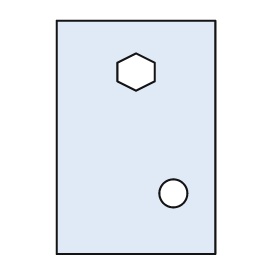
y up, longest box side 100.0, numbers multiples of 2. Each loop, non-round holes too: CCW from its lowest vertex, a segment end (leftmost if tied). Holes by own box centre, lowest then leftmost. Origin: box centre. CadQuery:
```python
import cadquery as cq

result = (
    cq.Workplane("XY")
    .moveTo(-34.0, -50.0)
    .lineTo(34.0, -50.0)
    .lineTo(34.0, 50.0)
    .lineTo(-34.0, 50.0)
    .close()
    .moveTo(16.0, -24.0)
    .circle(6.0)
    .moveTo(0.0, 20.0)
    .lineTo(8.0, 24.0)
    .lineTo(8.0, 32.0)
    .lineTo(0.0, 36.0)
    .lineTo(-8.0, 32.0)
    .lineTo(-8.0, 24.0)
    .close()
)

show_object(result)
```